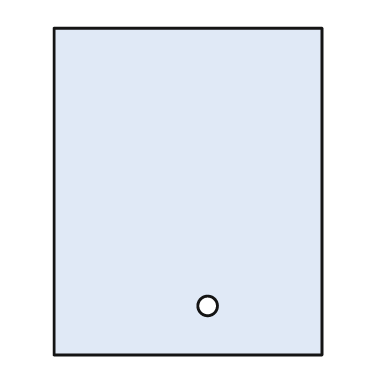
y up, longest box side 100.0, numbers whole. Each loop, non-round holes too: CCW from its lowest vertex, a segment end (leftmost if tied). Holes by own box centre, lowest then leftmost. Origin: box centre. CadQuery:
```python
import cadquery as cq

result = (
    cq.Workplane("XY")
    .moveTo(-41.0, -50.0)
    .lineTo(41.0, -50.0)
    .lineTo(41.0, 50.0)
    .lineTo(-41.0, 50.0)
    .close()
    .moveTo(6.0, -35.0)
    .circle(3.0)
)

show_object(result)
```